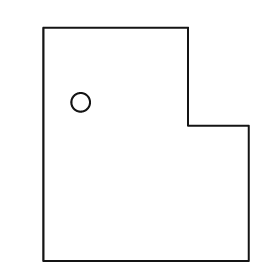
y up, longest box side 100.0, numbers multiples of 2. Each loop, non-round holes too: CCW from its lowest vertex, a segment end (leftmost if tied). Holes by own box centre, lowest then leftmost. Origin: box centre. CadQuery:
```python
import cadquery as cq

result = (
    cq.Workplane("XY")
    .moveTo(-44.0, -50.0)
    .lineTo(44.0, -50.0)
    .lineTo(44.0, 8.0)
    .lineTo(18.0, 8.0)
    .lineTo(18.0, 50.0)
    .lineTo(-44.0, 50.0)
    .close()
    .moveTo(-28.0, 18.0)
    .circle(4.0)
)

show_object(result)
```